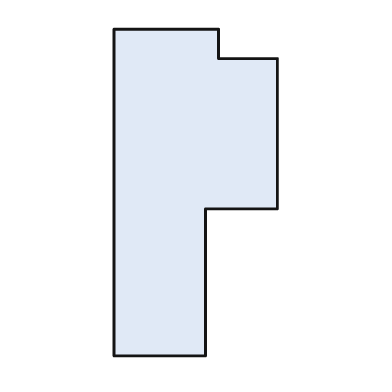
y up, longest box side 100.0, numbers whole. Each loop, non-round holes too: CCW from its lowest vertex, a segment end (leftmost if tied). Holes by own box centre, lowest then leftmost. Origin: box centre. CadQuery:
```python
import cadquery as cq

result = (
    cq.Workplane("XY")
    .moveTo(-25.0, -50.0)
    .lineTo(3.0, -50.0)
    .lineTo(3.0, -5.0)
    .lineTo(25.0, -5.0)
    .lineTo(25.0, 41.0)
    .lineTo(7.0, 41.0)
    .lineTo(7.0, 50.0)
    .lineTo(-25.0, 50.0)
    .close()
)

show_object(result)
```